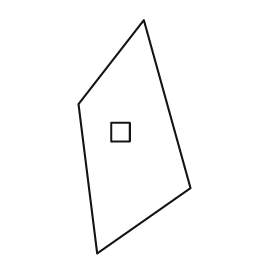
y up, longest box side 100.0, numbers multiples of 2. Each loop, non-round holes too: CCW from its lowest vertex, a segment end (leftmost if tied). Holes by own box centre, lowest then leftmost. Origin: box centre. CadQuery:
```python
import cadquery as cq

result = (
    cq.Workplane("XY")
    .moveTo(-16.0, -50.0)
    .lineTo(24.0, -22.0)
    .lineTo(4.0, 50.0)
    .lineTo(-24.0, 14.0)
    .close()
    .moveTo(-10.0, -2.0)
    .lineTo(-2.0, -2.0)
    .lineTo(-2.0, 6.0)
    .lineTo(-10.0, 6.0)
    .close()
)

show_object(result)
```